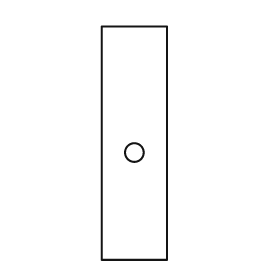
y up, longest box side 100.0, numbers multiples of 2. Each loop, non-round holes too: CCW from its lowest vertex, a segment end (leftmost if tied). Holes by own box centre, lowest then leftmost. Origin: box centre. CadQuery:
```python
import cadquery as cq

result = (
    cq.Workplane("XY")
    .moveTo(-14.0, -50.0)
    .lineTo(14.0, -50.0)
    .lineTo(14.0, 50.0)
    .lineTo(-14.0, 50.0)
    .close()
    .moveTo(0.0, -4.0)
    .circle(4.0)
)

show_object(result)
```